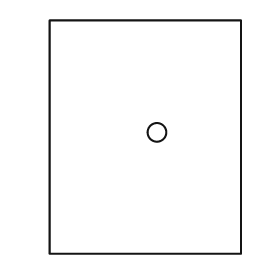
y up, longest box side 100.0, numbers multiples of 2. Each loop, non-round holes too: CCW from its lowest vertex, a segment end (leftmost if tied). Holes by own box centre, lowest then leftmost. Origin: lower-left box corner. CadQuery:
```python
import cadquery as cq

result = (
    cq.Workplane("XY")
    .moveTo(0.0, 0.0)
    .lineTo(82.0, 0.0)
    .lineTo(82.0, 100.0)
    .lineTo(0.0, 100.0)
    .close()
    .moveTo(46.0, 52.0)
    .circle(4.0)
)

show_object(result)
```